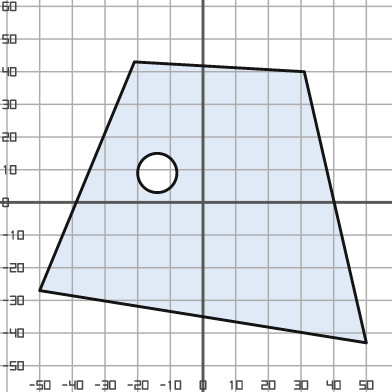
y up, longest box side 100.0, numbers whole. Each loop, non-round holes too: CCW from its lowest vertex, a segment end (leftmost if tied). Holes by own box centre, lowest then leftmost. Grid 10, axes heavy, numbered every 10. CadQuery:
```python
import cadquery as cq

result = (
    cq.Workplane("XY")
    .moveTo(50.0, -43.0)
    .lineTo(31.0, 40.0)
    .lineTo(-21.0, 43.0)
    .lineTo(-50.0, -27.0)
    .close()
    .moveTo(-14.0, 9.0)
    .circle(6.0)
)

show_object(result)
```